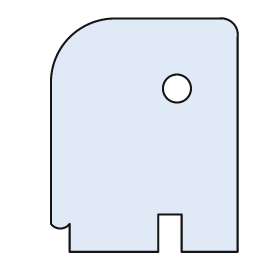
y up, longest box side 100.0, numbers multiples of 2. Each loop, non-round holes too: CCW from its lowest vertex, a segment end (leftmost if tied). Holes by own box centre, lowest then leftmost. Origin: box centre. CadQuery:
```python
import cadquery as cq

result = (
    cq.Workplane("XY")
    .moveTo(-32.0, -50.0)
    .lineTo(6.0, -50.0)
    .lineTo(6.0, -34.0)
    .lineTo(16.0, -34.0)
    .lineTo(16.0, -50.0)
    .lineTo(40.0, -50.0)
    .lineTo(40.0, 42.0)
    .threePointArc((38.0, 48.0), (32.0, 50.0))
    .lineTo(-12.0, 50.0)
    .threePointArc((-32.0, 42.0), (-40.0, 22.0))
    .lineTo(-40.0, -38.0)
    .threePointArc((-36.0, -40.0), (-32.0, -38.0))
    .close()
    .moveTo(14.0, 20.0)
    .circle(6.0)
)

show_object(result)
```